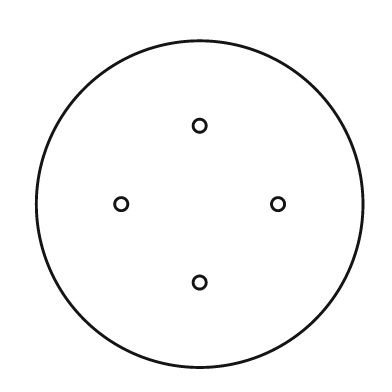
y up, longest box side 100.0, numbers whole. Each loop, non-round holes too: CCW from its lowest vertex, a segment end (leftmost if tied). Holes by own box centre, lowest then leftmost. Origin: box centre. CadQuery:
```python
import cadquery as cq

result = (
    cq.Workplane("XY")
    .moveTo(0.0, 0.0)
    .circle(50.0)
    .moveTo(0.0, -24.0)
    .circle(2.0)
    .moveTo(-24.0, 0.0)
    .circle(2.0)
    .moveTo(24.0, 0.0)
    .circle(2.0)
    .moveTo(0.0, 24.0)
    .circle(2.0)
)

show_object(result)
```